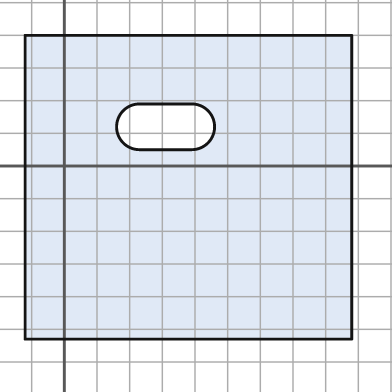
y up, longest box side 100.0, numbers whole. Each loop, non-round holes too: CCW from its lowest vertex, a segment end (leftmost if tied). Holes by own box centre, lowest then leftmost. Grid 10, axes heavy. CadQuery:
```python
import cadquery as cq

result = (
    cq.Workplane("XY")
    .moveTo(-12.0, -53.0)
    .lineTo(88.0, -53.0)
    .lineTo(88.0, 40.0)
    .lineTo(-12.0, 40.0)
    .close()
    .moveTo(23.0, 5.0)
    .lineTo(39.0, 5.0)
    .threePointArc((46.0, 12.0), (39.0, 19.0))
    .lineTo(23.0, 19.0)
    .threePointArc((16.0, 12.0), (23.0, 5.0))
    .close()
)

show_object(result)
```